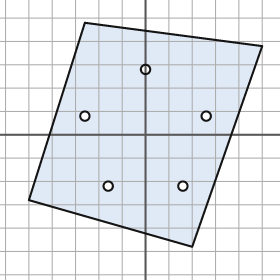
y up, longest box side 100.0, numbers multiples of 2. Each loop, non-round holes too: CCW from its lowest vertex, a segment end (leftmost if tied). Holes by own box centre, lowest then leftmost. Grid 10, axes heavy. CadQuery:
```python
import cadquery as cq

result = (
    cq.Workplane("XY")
    .moveTo(20.0, -48.0)
    .lineTo(50.0, 38.0)
    .lineTo(-26.0, 48.0)
    .lineTo(-50.0, -28.0)
    .close()
    .moveTo(-16.0, -22.0)
    .circle(2.0)
    .moveTo(16.0, -22.0)
    .circle(2.0)
    .moveTo(-26.0, 8.0)
    .circle(2.0)
    .moveTo(26.0, 8.0)
    .circle(2.0)
    .moveTo(0.0, 28.0)
    .circle(2.0)
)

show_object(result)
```